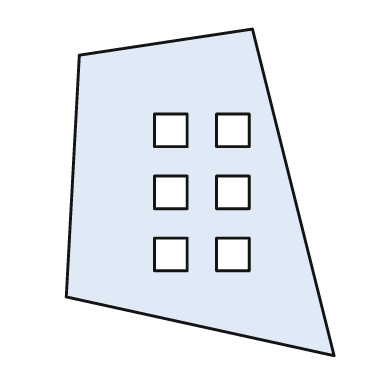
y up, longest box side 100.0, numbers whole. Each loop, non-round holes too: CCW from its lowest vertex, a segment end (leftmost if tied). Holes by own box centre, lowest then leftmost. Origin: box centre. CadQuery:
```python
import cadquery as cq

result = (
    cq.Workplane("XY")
    .moveTo(41.0, -50.0)
    .lineTo(16.0, 50.0)
    .lineTo(-37.0, 42.0)
    .lineTo(-41.0, -32.0)
    .close()
    .moveTo(-14.0, -24.0)
    .lineTo(-4.0, -24.0)
    .lineTo(-4.0, -14.0)
    .lineTo(-14.0, -14.0)
    .close()
    .moveTo(5.0, -24.0)
    .lineTo(15.0, -24.0)
    .lineTo(15.0, -14.0)
    .lineTo(5.0, -14.0)
    .close()
    .moveTo(-14.0, -5.0)
    .lineTo(-4.0, -5.0)
    .lineTo(-4.0, 5.0)
    .lineTo(-14.0, 5.0)
    .close()
    .moveTo(5.0, -5.0)
    .lineTo(15.0, -5.0)
    .lineTo(15.0, 5.0)
    .lineTo(5.0, 5.0)
    .close()
    .moveTo(-14.0, 14.0)
    .lineTo(-4.0, 14.0)
    .lineTo(-4.0, 24.0)
    .lineTo(-14.0, 24.0)
    .close()
    .moveTo(5.0, 14.0)
    .lineTo(15.0, 14.0)
    .lineTo(15.0, 24.0)
    .lineTo(5.0, 24.0)
    .close()
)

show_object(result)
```